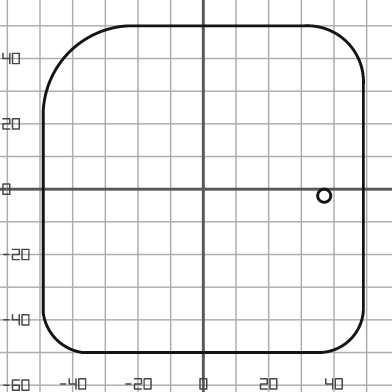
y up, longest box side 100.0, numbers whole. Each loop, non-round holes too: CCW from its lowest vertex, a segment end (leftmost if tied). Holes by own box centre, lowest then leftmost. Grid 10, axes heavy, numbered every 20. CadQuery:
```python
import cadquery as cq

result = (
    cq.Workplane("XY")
    .moveTo(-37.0, -50.0)
    .lineTo(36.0, -50.0)
    .threePointArc((45.0, -46.0), (49.0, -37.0))
    .lineTo(49.0, 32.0)
    .threePointArc((44.0, 45.0), (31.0, 50.0))
    .lineTo(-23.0, 50.0)
    .threePointArc((-41.0, 42.0), (-49.0, 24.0))
    .lineTo(-49.0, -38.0)
    .threePointArc((-45.0, -46.0), (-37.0, -50.0))
    .close()
    .moveTo(37.0, -2.0)
    .circle(2.0)
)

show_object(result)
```